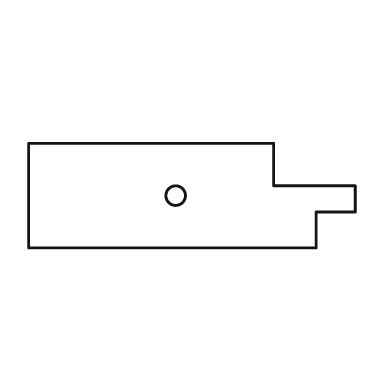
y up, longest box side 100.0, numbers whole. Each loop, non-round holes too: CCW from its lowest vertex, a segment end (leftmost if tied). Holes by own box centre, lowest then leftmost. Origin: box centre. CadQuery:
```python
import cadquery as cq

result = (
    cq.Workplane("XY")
    .moveTo(-50.0, -16.0)
    .lineTo(38.0, -16.0)
    .lineTo(38.0, -5.0)
    .lineTo(50.0, -5.0)
    .lineTo(50.0, 3.0)
    .lineTo(25.0, 3.0)
    .lineTo(25.0, 16.0)
    .lineTo(-50.0, 16.0)
    .close()
    .moveTo(-5.0, 0.0)
    .circle(3.0)
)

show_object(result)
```